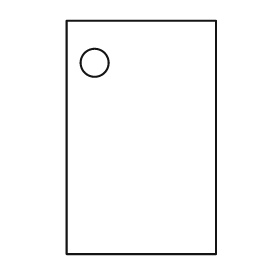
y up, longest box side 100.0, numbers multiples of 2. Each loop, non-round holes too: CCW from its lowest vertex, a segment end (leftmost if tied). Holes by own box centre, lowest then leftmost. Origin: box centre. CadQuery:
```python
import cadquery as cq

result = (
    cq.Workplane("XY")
    .moveTo(-32.0, -50.0)
    .lineTo(32.0, -50.0)
    .lineTo(32.0, 50.0)
    .lineTo(-32.0, 50.0)
    .close()
    .moveTo(-20.0, 32.0)
    .circle(6.0)
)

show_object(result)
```